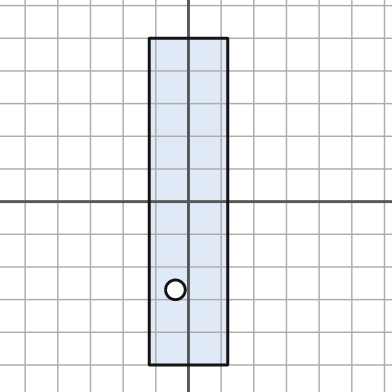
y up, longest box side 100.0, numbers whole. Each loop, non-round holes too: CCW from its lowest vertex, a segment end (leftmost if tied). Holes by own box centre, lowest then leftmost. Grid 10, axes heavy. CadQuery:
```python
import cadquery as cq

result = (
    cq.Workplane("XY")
    .moveTo(-12.0, -50.0)
    .lineTo(12.0, -50.0)
    .lineTo(12.0, 50.0)
    .lineTo(-12.0, 50.0)
    .close()
    .moveTo(-4.0, -27.0)
    .circle(3.0)
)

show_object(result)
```